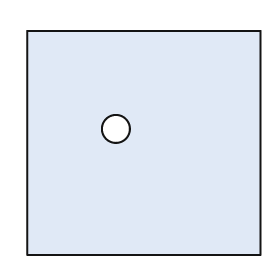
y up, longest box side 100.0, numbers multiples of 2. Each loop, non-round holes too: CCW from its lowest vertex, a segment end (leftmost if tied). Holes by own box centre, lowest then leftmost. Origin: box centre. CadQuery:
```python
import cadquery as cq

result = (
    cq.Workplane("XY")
    .moveTo(-50.0, -48.0)
    .lineTo(50.0, -48.0)
    .lineTo(50.0, 48.0)
    .lineTo(-50.0, 48.0)
    .close()
    .moveTo(-12.0, 6.0)
    .circle(6.0)
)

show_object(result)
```